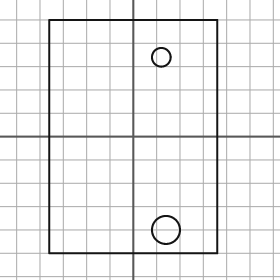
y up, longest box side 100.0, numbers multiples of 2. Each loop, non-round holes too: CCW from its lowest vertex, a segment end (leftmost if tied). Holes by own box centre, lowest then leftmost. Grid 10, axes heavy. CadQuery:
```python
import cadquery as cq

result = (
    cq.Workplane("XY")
    .moveTo(-36.0, -50.0)
    .lineTo(36.0, -50.0)
    .lineTo(36.0, 50.0)
    .lineTo(-36.0, 50.0)
    .close()
    .moveTo(14.0, -40.0)
    .circle(6.0)
    .moveTo(12.0, 34.0)
    .circle(4.0)
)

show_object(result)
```